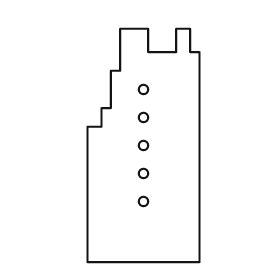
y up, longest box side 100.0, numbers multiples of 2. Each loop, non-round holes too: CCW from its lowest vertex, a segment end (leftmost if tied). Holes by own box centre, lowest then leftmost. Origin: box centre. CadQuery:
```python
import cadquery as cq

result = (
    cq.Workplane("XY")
    .moveTo(-24.0, -50.0)
    .lineTo(24.0, -50.0)
    .lineTo(24.0, 40.0)
    .lineTo(20.0, 40.0)
    .lineTo(20.0, 50.0)
    .lineTo(14.0, 50.0)
    .lineTo(14.0, 40.0)
    .lineTo(2.0, 40.0)
    .lineTo(2.0, 50.0)
    .lineTo(-10.0, 50.0)
    .lineTo(-10.0, 32.0)
    .lineTo(-14.0, 32.0)
    .lineTo(-14.0, 16.0)
    .lineTo(-18.0, 16.0)
    .lineTo(-18.0, 8.0)
    .lineTo(-24.0, 8.0)
    .close()
    .moveTo(0.0, -24.0)
    .circle(2.0)
    .moveTo(0.0, -12.0)
    .circle(2.0)
    .moveTo(0.0, 0.0)
    .circle(2.0)
    .moveTo(0.0, 12.0)
    .circle(2.0)
    .moveTo(0.0, 24.0)
    .circle(2.0)
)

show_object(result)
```